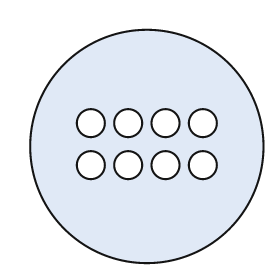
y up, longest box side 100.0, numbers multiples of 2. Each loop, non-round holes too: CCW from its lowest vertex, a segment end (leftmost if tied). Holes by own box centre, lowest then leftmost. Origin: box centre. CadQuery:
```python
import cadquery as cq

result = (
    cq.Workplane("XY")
    .moveTo(0.0, 0.0)
    .circle(50.0)
    .moveTo(-24.0, -8.0)
    .circle(6.0)
    .moveTo(-8.0, -8.0)
    .circle(6.0)
    .moveTo(8.0, -8.0)
    .circle(6.0)
    .moveTo(24.0, -8.0)
    .circle(6.0)
    .moveTo(-24.0, 10.0)
    .circle(6.0)
    .moveTo(-8.0, 10.0)
    .circle(6.0)
    .moveTo(8.0, 10.0)
    .circle(6.0)
    .moveTo(24.0, 10.0)
    .circle(6.0)
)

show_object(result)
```